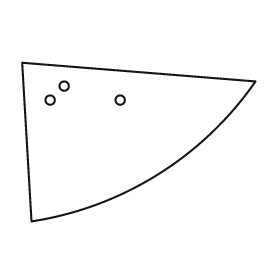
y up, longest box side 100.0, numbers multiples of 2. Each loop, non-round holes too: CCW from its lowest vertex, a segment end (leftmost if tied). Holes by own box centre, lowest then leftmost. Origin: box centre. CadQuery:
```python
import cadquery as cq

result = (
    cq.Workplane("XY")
    .moveTo(-46.0, -34.0)
    .threePointArc((8.0, -14.0), (50.0, 26.0))
    .lineTo(-50.0, 34.0)
    .close()
    .moveTo(-38.0, 18.0)
    .circle(2.0)
    .moveTo(-8.0, 18.0)
    .circle(2.0)
    .moveTo(-32.0, 24.0)
    .circle(2.0)
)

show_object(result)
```